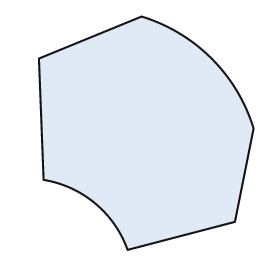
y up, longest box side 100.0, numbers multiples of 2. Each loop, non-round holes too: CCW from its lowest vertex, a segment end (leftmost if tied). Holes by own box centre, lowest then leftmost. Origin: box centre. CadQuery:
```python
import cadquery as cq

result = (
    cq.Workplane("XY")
    .moveTo(-8.0, -50.0)
    .lineTo(38.0, -38.0)
    .lineTo(46.0, 2.0)
    .threePointArc((28.0, 32.0), (-2.0, 50.0))
    .lineTo(-46.0, 32.0)
    .lineTo(-44.0, -20.0)
    .threePointArc((-22.0, -30.0), (-8.0, -50.0))
    .close()
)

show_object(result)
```